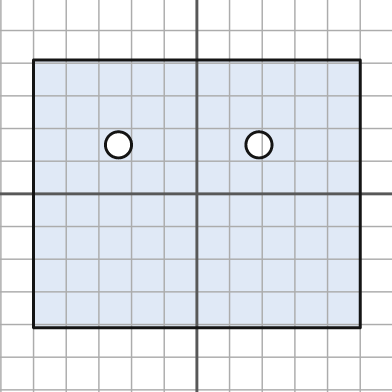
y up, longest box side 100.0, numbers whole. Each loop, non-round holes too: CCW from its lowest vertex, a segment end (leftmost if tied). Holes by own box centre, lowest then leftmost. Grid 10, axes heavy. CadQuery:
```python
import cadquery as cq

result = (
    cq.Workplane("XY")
    .moveTo(-50.0, -41.0)
    .lineTo(50.0, -41.0)
    .lineTo(50.0, 41.0)
    .lineTo(-50.0, 41.0)
    .close()
    .moveTo(-24.0, 15.0)
    .circle(4.0)
    .moveTo(19.0, 15.0)
    .circle(4.0)
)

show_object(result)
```